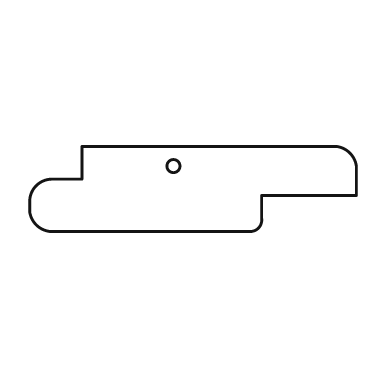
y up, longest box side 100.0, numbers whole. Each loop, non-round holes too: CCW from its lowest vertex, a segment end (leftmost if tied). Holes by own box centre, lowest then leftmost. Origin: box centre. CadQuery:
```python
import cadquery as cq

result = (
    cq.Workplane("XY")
    .moveTo(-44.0, -13.0)
    .lineTo(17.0, -13.0)
    .threePointArc((20.0, -12.0), (21.0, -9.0))
    .lineTo(21.0, -2.0)
    .lineTo(50.0, -2.0)
    .lineTo(50.0, 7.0)
    .threePointArc((48.0, 11.0), (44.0, 13.0))
    .lineTo(-34.0, 13.0)
    .lineTo(-34.0, 3.0)
    .lineTo(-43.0, 3.0)
    .threePointArc((-48.0, 1.0), (-50.0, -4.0))
    .lineTo(-50.0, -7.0)
    .threePointArc((-48.0, -11.0), (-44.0, -13.0))
    .close()
    .moveTo(-6.0, 7.0)
    .circle(2.0)
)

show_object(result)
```